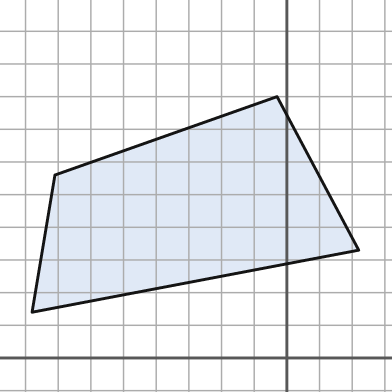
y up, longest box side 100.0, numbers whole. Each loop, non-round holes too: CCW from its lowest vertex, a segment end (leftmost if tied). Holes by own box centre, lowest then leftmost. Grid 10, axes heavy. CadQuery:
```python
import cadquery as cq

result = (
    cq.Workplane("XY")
    .moveTo(-78.0, 14.0)
    .lineTo(22.0, 33.0)
    .lineTo(-3.0, 80.0)
    .lineTo(-71.0, 56.0)
    .close()
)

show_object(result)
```